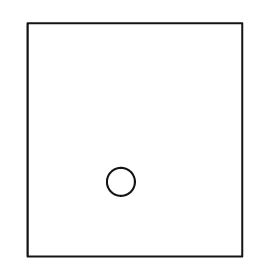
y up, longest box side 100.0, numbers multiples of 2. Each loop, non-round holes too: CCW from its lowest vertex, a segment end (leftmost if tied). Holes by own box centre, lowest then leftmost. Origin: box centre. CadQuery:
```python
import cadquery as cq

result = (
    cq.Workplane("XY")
    .moveTo(-46.0, -50.0)
    .lineTo(46.0, -50.0)
    .lineTo(46.0, 50.0)
    .lineTo(-46.0, 50.0)
    .close()
    .moveTo(-6.0, -18.0)
    .circle(6.0)
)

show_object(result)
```